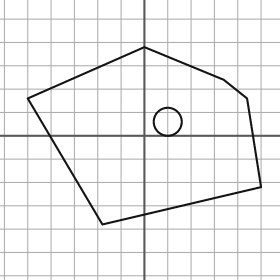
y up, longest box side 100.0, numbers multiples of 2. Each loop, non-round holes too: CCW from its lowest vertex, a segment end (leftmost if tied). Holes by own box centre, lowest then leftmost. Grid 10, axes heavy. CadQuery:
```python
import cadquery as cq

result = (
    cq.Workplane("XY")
    .moveTo(-18.0, -38.0)
    .lineTo(50.0, -22.0)
    .lineTo(44.0, 16.0)
    .lineTo(34.0, 24.0)
    .lineTo(0.0, 38.0)
    .lineTo(-50.0, 16.0)
    .close()
    .moveTo(10.0, 6.0)
    .circle(6.0)
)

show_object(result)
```